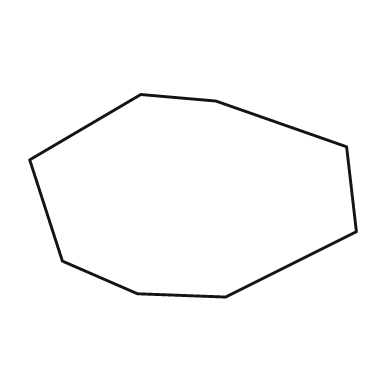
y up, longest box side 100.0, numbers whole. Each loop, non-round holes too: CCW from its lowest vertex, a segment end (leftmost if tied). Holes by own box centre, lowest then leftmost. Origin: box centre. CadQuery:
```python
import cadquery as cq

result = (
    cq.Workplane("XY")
    .moveTo(10.0, -31.0)
    .lineTo(50.0, -11.0)
    .lineTo(47.0, 15.0)
    .lineTo(7.0, 29.0)
    .lineTo(-16.0, 31.0)
    .lineTo(-50.0, 11.0)
    .lineTo(-40.0, -20.0)
    .lineTo(-17.0, -30.0)
    .close()
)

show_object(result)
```